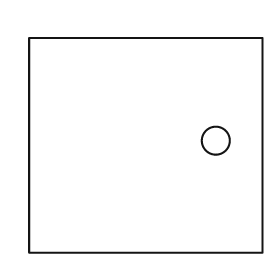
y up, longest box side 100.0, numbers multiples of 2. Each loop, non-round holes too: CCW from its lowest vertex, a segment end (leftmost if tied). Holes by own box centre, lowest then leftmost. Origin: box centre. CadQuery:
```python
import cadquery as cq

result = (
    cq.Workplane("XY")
    .moveTo(-50.0, -46.0)
    .lineTo(50.0, -46.0)
    .lineTo(50.0, 46.0)
    .lineTo(-50.0, 46.0)
    .close()
    .moveTo(30.0, 2.0)
    .circle(6.0)
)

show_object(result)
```